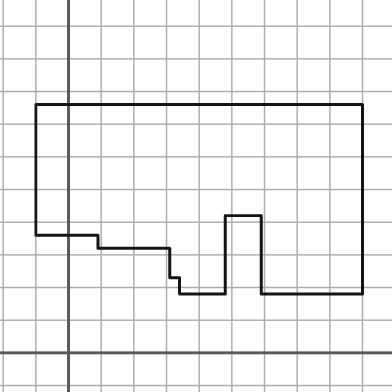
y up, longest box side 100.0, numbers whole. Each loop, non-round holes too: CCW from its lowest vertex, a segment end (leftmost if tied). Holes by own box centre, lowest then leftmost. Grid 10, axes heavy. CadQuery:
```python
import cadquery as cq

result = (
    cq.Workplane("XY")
    .moveTo(34.0, 18.0)
    .lineTo(48.0, 18.0)
    .lineTo(48.0, 42.0)
    .lineTo(59.0, 42.0)
    .lineTo(59.0, 18.0)
    .lineTo(90.0, 18.0)
    .lineTo(90.0, 76.0)
    .lineTo(-10.0, 76.0)
    .lineTo(-10.0, 36.0)
    .lineTo(9.0, 36.0)
    .lineTo(9.0, 32.0)
    .lineTo(31.0, 32.0)
    .lineTo(31.0, 23.0)
    .lineTo(34.0, 23.0)
    .close()
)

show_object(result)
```